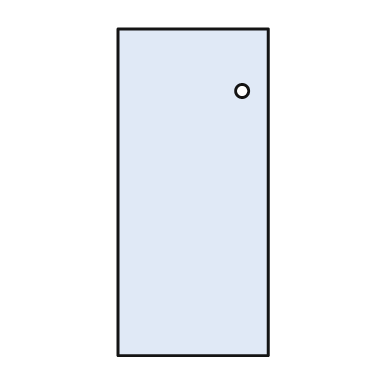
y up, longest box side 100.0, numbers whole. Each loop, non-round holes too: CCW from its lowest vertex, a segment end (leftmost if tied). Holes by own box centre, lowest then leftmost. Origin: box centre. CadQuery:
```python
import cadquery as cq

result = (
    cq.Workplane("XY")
    .moveTo(-23.0, -50.0)
    .lineTo(23.0, -50.0)
    .lineTo(23.0, 50.0)
    .lineTo(-23.0, 50.0)
    .close()
    .moveTo(15.0, 31.0)
    .circle(2.0)
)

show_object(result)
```